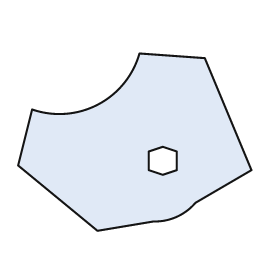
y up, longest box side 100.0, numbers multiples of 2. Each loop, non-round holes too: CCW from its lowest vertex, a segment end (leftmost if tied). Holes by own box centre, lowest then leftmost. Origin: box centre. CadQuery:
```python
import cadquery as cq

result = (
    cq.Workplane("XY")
    .moveTo(-16.0, -38.0)
    .lineTo(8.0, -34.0)
    .threePointArc((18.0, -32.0), (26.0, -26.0))
    .lineTo(50.0, -12.0)
    .lineTo(30.0, 36.0)
    .lineTo(2.0, 38.0)
    .threePointArc((-16.0, 16.0), (-44.0, 14.0))
    .lineTo(-50.0, -10.0)
    .close()
    .moveTo(12.0, -14.0)
    .lineTo(18.0, -12.0)
    .lineTo(18.0, -4.0)
    .lineTo(12.0, -2.0)
    .lineTo(6.0, -4.0)
    .lineTo(6.0, -12.0)
    .close()
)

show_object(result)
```